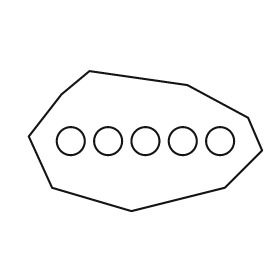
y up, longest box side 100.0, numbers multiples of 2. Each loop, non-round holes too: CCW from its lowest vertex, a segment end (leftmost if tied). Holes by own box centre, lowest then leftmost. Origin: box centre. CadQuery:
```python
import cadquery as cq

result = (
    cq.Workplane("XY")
    .moveTo(-6.0, -30.0)
    .lineTo(34.0, -20.0)
    .lineTo(50.0, -4.0)
    .lineTo(44.0, 10.0)
    .lineTo(18.0, 24.0)
    .lineTo(-24.0, 30.0)
    .lineTo(-36.0, 20.0)
    .lineTo(-50.0, 2.0)
    .lineTo(-40.0, -20.0)
    .close()
    .moveTo(-32.0, 0.0)
    .circle(6.0)
    .moveTo(-16.0, 0.0)
    .circle(6.0)
    .moveTo(0.0, 0.0)
    .circle(6.0)
    .moveTo(16.0, 0.0)
    .circle(6.0)
    .moveTo(32.0, 0.0)
    .circle(6.0)
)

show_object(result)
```